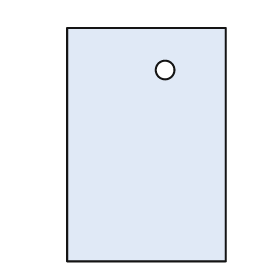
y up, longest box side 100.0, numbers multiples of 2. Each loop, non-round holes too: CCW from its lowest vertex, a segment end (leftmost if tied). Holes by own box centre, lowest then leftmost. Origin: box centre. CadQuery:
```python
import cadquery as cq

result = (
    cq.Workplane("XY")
    .moveTo(-34.0, -50.0)
    .lineTo(34.0, -50.0)
    .lineTo(34.0, 50.0)
    .lineTo(-34.0, 50.0)
    .close()
    .moveTo(8.0, 32.0)
    .circle(4.0)
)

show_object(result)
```